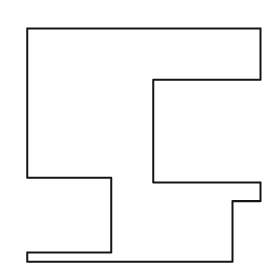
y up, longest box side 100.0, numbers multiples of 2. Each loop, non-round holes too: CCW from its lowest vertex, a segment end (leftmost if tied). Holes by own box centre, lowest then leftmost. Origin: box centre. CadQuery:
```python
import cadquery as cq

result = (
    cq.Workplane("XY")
    .moveTo(-50.0, -50.0)
    .lineTo(38.0, -50.0)
    .lineTo(38.0, -24.0)
    .lineTo(50.0, -24.0)
    .lineTo(50.0, -16.0)
    .lineTo(4.0, -16.0)
    .lineTo(4.0, 28.0)
    .lineTo(50.0, 28.0)
    .lineTo(50.0, 50.0)
    .lineTo(-50.0, 50.0)
    .lineTo(-50.0, -14.0)
    .lineTo(-14.0, -14.0)
    .lineTo(-14.0, -46.0)
    .lineTo(-50.0, -46.0)
    .close()
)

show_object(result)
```